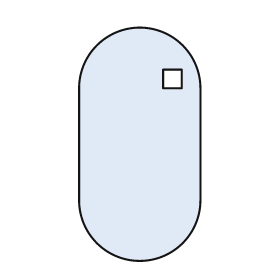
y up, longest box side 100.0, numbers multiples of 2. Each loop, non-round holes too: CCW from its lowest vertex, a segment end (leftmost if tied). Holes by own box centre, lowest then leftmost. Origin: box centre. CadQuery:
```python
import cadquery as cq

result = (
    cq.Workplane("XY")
    .moveTo(-26.0, -24.0)
    .threePointArc((0.0, -50.0), (26.0, -24.0))
    .lineTo(26.0, 24.0)
    .threePointArc((0.0, 50.0), (-26.0, 24.0))
    .close()
    .moveTo(10.0, 24.0)
    .lineTo(18.0, 24.0)
    .lineTo(18.0, 32.0)
    .lineTo(10.0, 32.0)
    .close()
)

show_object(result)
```